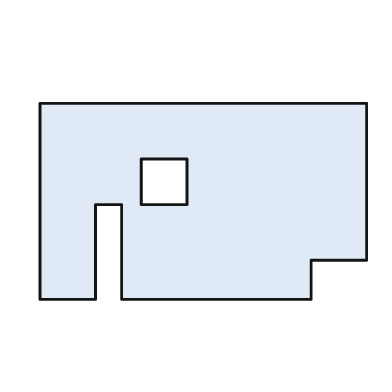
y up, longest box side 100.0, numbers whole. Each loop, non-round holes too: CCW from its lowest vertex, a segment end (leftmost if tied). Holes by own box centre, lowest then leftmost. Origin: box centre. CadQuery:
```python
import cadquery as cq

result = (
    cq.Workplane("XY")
    .moveTo(-50.0, -30.0)
    .lineTo(-33.0, -30.0)
    .lineTo(-33.0, -1.0)
    .lineTo(-25.0, -1.0)
    .lineTo(-25.0, -30.0)
    .lineTo(33.0, -30.0)
    .lineTo(33.0, -18.0)
    .lineTo(50.0, -18.0)
    .lineTo(50.0, 30.0)
    .lineTo(-50.0, 30.0)
    .close()
    .moveTo(-19.0, -1.0)
    .lineTo(-5.0, -1.0)
    .lineTo(-5.0, 13.0)
    .lineTo(-19.0, 13.0)
    .close()
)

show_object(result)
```